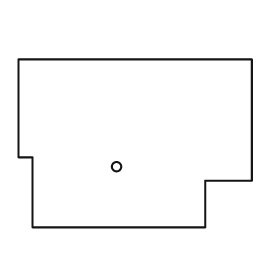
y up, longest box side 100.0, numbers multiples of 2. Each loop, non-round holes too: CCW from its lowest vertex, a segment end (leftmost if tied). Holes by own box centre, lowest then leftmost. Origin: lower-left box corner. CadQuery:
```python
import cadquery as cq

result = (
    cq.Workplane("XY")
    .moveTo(6.0, 0.0)
    .lineTo(80.0, 0.0)
    .lineTo(80.0, 20.0)
    .lineTo(100.0, 20.0)
    .lineTo(100.0, 72.0)
    .lineTo(0.0, 72.0)
    .lineTo(0.0, 30.0)
    .lineTo(6.0, 30.0)
    .close()
    .moveTo(42.0, 26.0)
    .circle(2.0)
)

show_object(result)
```